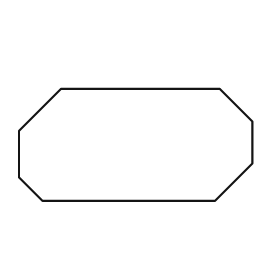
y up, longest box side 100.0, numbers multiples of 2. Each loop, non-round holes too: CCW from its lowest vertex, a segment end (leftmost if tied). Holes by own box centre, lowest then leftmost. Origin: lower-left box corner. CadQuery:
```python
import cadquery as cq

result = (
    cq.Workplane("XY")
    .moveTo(10.0, 0.0)
    .lineTo(84.0, 0.0)
    .lineTo(100.0, 16.0)
    .lineTo(100.0, 34.0)
    .lineTo(86.0, 48.0)
    .lineTo(18.0, 48.0)
    .lineTo(0.0, 30.0)
    .lineTo(0.0, 10.0)
    .close()
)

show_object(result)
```